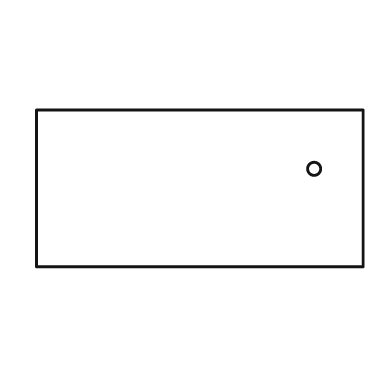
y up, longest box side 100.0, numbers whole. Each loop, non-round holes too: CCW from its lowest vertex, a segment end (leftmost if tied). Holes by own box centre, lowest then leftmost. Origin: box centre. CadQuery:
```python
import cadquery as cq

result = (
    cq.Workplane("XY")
    .moveTo(-50.0, -24.0)
    .lineTo(50.0, -24.0)
    .lineTo(50.0, 24.0)
    .lineTo(-50.0, 24.0)
    .close()
    .moveTo(35.0, 6.0)
    .circle(2.0)
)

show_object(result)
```